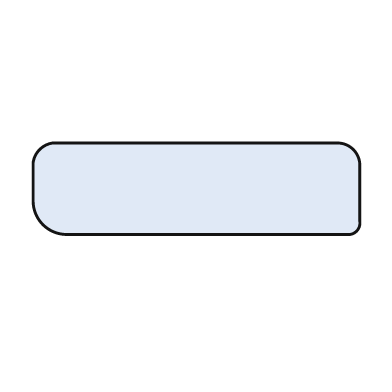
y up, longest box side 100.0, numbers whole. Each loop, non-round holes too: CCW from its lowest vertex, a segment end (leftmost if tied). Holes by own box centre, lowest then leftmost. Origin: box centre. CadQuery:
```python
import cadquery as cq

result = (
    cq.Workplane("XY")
    .moveTo(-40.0, -14.0)
    .lineTo(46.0, -14.0)
    .threePointArc((49.0, -13.0), (50.0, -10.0))
    .lineTo(50.0, 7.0)
    .threePointArc((48.0, 12.0), (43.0, 14.0))
    .lineTo(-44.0, 14.0)
    .threePointArc((-48.0, 12.0), (-50.0, 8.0))
    .lineTo(-50.0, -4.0)
    .threePointArc((-47.0, -11.0), (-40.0, -14.0))
    .close()
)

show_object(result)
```